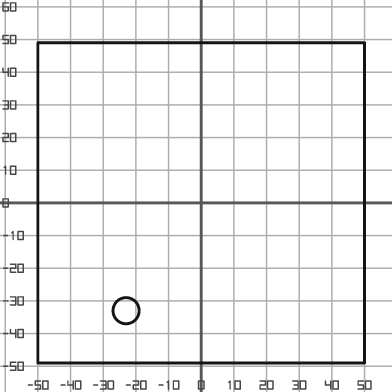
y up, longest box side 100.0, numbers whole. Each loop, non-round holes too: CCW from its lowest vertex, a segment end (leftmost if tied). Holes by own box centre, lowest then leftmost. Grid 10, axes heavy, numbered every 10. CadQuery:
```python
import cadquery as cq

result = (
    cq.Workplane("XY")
    .moveTo(-50.0, -49.0)
    .lineTo(50.0, -49.0)
    .lineTo(50.0, 49.0)
    .lineTo(-50.0, 49.0)
    .close()
    .moveTo(-23.0, -33.0)
    .circle(4.0)
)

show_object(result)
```